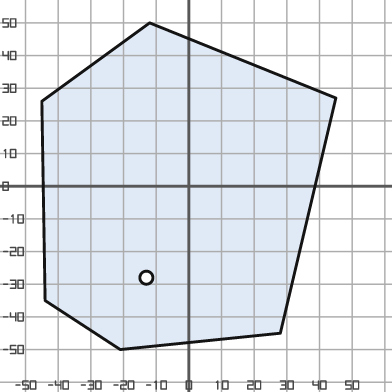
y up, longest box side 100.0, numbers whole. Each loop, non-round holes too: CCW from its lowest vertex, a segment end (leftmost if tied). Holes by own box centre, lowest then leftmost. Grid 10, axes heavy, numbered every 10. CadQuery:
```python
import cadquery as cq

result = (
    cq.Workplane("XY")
    .moveTo(-21.0, -50.0)
    .lineTo(28.0, -45.0)
    .lineTo(45.0, 27.0)
    .lineTo(-12.0, 50.0)
    .lineTo(-45.0, 26.0)
    .lineTo(-44.0, -35.0)
    .close()
    .moveTo(-13.0, -28.0)
    .circle(2.0)
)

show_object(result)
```